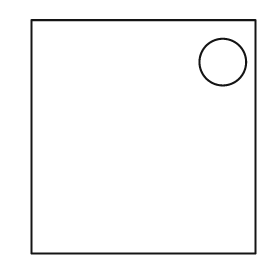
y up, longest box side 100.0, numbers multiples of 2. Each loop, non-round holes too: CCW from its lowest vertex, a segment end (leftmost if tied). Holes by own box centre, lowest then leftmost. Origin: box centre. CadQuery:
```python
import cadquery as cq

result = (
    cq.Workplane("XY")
    .moveTo(-48.0, -50.0)
    .lineTo(48.0, -50.0)
    .lineTo(48.0, 50.0)
    .lineTo(-48.0, 50.0)
    .close()
    .moveTo(34.0, 32.0)
    .circle(10.0)
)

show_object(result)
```